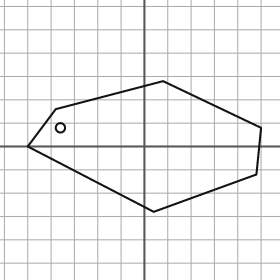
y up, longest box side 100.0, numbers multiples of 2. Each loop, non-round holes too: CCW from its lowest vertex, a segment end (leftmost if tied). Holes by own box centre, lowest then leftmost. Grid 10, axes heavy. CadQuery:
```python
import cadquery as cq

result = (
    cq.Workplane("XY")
    .moveTo(4.0, -28.0)
    .lineTo(48.0, -12.0)
    .lineTo(50.0, 8.0)
    .lineTo(8.0, 28.0)
    .lineTo(-38.0, 16.0)
    .lineTo(-50.0, 0.0)
    .close()
    .moveTo(-36.0, 8.0)
    .circle(2.0)
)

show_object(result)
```